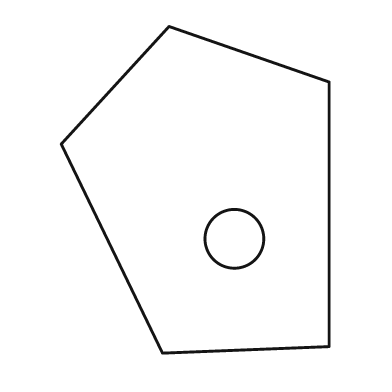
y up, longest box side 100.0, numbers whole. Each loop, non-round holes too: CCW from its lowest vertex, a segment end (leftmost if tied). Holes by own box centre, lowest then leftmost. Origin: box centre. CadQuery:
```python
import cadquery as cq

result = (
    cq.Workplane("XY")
    .moveTo(-10.0, -50.0)
    .lineTo(41.0, -48.0)
    .lineTo(41.0, 33.0)
    .lineTo(-8.0, 50.0)
    .lineTo(-41.0, 14.0)
    .close()
    .moveTo(12.0, -15.0)
    .circle(9.0)
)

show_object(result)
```